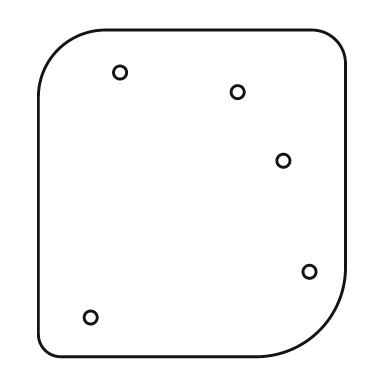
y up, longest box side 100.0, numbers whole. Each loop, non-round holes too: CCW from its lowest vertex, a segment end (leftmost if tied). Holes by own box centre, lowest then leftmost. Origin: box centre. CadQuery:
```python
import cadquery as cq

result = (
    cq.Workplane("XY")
    .moveTo(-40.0, -50.0)
    .lineTo(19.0, -50.0)
    .threePointArc((39.0, -42.0), (47.0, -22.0))
    .lineTo(47.0, 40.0)
    .threePointArc((44.0, 47.0), (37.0, 50.0))
    .lineTo(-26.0, 50.0)
    .threePointArc((-41.0, 44.0), (-47.0, 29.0))
    .lineTo(-47.0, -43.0)
    .threePointArc((-45.0, -48.0), (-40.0, -50.0))
    .close()
    .moveTo(-31.0, -38.0)
    .circle(2.0)
    .moveTo(36.0, -24.0)
    .circle(2.0)
    .moveTo(28.0, 10.0)
    .circle(2.0)
    .moveTo(14.0, 31.0)
    .circle(2.0)
    .moveTo(-22.0, 37.0)
    .circle(2.0)
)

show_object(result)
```